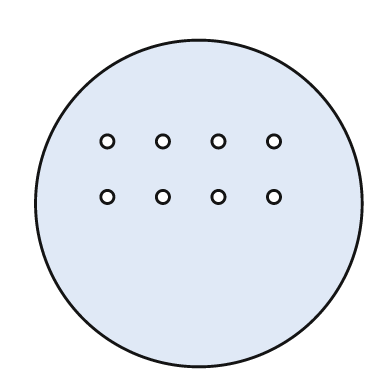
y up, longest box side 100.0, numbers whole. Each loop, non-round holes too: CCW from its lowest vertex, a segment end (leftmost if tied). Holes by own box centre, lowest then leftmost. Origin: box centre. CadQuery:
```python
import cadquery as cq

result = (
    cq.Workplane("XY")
    .moveTo(0.0, 0.0)
    .circle(50.0)
    .moveTo(-28.0, 2.0)
    .circle(2.0)
    .moveTo(-11.0, 2.0)
    .circle(2.0)
    .moveTo(6.0, 2.0)
    .circle(2.0)
    .moveTo(23.0, 2.0)
    .circle(2.0)
    .moveTo(-28.0, 19.0)
    .circle(2.0)
    .moveTo(-11.0, 19.0)
    .circle(2.0)
    .moveTo(6.0, 19.0)
    .circle(2.0)
    .moveTo(23.0, 19.0)
    .circle(2.0)
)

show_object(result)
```